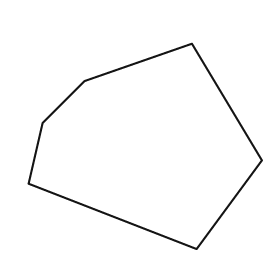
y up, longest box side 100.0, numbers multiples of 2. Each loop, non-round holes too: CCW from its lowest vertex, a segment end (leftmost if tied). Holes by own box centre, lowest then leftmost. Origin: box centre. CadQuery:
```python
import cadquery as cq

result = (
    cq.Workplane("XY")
    .moveTo(22.0, -44.0)
    .lineTo(50.0, -6.0)
    .lineTo(20.0, 44.0)
    .lineTo(-26.0, 28.0)
    .lineTo(-44.0, 10.0)
    .lineTo(-50.0, -16.0)
    .close()
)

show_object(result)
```